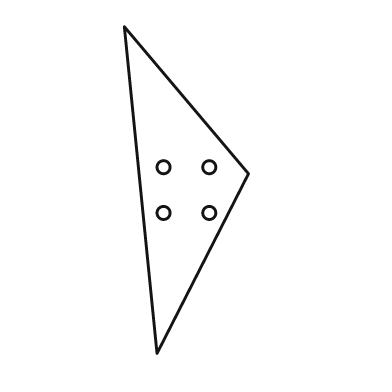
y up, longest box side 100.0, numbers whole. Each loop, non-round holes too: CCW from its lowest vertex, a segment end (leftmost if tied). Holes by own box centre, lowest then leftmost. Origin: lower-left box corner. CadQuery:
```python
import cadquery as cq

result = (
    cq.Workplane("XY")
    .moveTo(10.0, 0.0)
    .lineTo(38.0, 55.0)
    .lineTo(0.0, 100.0)
    .close()
    .moveTo(12.0, 43.0)
    .circle(2.0)
    .moveTo(26.0, 43.0)
    .circle(2.0)
    .moveTo(12.0, 57.0)
    .circle(2.0)
    .moveTo(26.0, 57.0)
    .circle(2.0)
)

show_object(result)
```